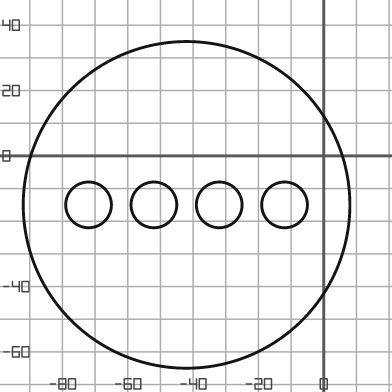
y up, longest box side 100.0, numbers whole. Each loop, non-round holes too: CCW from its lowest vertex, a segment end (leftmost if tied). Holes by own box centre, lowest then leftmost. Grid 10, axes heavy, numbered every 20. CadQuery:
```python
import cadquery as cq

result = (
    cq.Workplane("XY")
    .moveTo(-42.0, -15.0)
    .circle(50.0)
    .moveTo(-72.0, -15.0)
    .circle(7.0)
    .moveTo(-52.0, -15.0)
    .circle(7.0)
    .moveTo(-32.0, -15.0)
    .circle(7.0)
    .moveTo(-12.0, -15.0)
    .circle(7.0)
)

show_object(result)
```